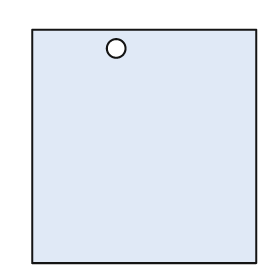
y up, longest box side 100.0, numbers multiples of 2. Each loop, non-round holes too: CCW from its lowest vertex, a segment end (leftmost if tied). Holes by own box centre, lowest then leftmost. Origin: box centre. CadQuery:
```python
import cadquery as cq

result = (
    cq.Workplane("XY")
    .moveTo(-48.0, -50.0)
    .lineTo(48.0, -50.0)
    .lineTo(48.0, 50.0)
    .lineTo(-48.0, 50.0)
    .close()
    .moveTo(-12.0, 42.0)
    .circle(4.0)
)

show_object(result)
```